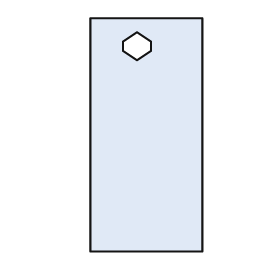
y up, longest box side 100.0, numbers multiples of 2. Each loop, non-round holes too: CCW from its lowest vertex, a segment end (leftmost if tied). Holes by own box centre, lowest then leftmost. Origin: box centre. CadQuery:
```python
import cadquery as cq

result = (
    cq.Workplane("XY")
    .moveTo(-24.0, -50.0)
    .lineTo(24.0, -50.0)
    .lineTo(24.0, 50.0)
    .lineTo(-24.0, 50.0)
    .close()
    .moveTo(-4.0, 32.0)
    .lineTo(2.0, 36.0)
    .lineTo(2.0, 40.0)
    .lineTo(-4.0, 44.0)
    .lineTo(-10.0, 40.0)
    .lineTo(-10.0, 36.0)
    .close()
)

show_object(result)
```